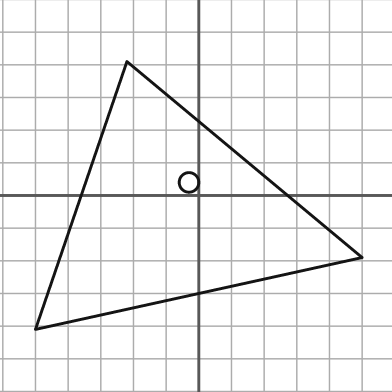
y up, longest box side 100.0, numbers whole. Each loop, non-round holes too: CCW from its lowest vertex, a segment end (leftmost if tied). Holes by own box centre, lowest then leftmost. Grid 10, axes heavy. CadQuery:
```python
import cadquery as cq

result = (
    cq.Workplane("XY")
    .moveTo(-50.0, -41.0)
    .lineTo(50.0, -19.0)
    .lineTo(-22.0, 41.0)
    .close()
    .moveTo(-3.0, 4.0)
    .circle(3.0)
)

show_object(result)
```